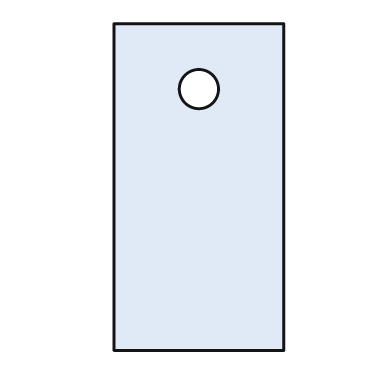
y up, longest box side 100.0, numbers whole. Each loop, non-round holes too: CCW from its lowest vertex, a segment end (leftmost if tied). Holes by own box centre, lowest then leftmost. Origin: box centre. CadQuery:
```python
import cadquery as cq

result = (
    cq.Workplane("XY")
    .moveTo(-26.0, -50.0)
    .lineTo(26.0, -50.0)
    .lineTo(26.0, 50.0)
    .lineTo(-26.0, 50.0)
    .close()
    .moveTo(0.0, 30.0)
    .circle(6.0)
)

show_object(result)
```